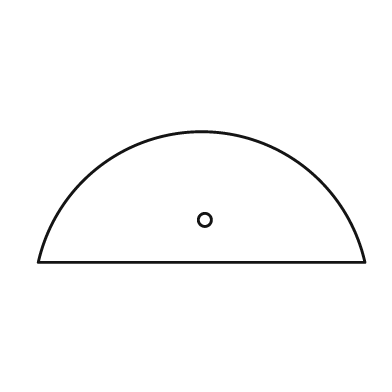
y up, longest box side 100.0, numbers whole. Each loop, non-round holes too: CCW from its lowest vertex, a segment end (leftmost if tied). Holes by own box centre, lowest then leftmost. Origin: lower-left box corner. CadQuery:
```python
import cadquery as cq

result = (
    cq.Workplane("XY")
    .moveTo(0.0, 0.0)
    .lineTo(100.0, 0.0)
    .threePointArc((50.0, 40.0), (0.0, 0.0))
    .close()
    .moveTo(51.0, 13.0)
    .circle(2.0)
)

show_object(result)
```